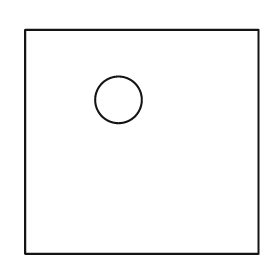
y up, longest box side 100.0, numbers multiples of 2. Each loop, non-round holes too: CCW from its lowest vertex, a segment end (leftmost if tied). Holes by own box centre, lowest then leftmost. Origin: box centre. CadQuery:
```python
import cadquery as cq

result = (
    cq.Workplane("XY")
    .moveTo(-50.0, -48.0)
    .lineTo(50.0, -48.0)
    .lineTo(50.0, 48.0)
    .lineTo(-50.0, 48.0)
    .close()
    .moveTo(-10.0, 18.0)
    .circle(10.0)
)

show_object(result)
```